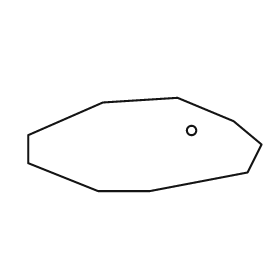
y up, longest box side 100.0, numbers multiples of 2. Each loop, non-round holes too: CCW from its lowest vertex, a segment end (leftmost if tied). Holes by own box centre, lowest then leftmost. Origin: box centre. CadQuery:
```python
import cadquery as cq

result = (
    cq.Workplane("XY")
    .moveTo(-20.0, -20.0)
    .lineTo(2.0, -20.0)
    .lineTo(44.0, -12.0)
    .lineTo(50.0, 0.0)
    .lineTo(38.0, 10.0)
    .lineTo(14.0, 20.0)
    .lineTo(-18.0, 18.0)
    .lineTo(-50.0, 4.0)
    .lineTo(-50.0, -8.0)
    .close()
    .moveTo(20.0, 6.0)
    .circle(2.0)
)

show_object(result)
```